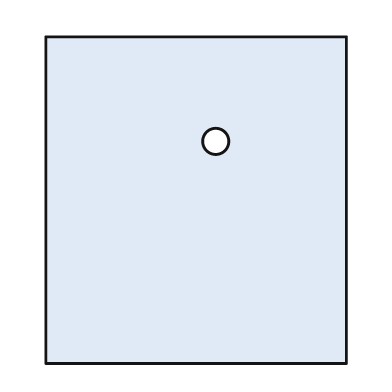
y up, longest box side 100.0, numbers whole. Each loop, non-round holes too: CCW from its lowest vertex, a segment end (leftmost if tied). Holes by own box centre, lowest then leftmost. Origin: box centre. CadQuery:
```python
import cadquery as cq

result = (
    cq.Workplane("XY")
    .moveTo(-46.0, -50.0)
    .lineTo(46.0, -50.0)
    .lineTo(46.0, 50.0)
    .lineTo(-46.0, 50.0)
    .close()
    .moveTo(6.0, 18.0)
    .circle(4.0)
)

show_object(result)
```